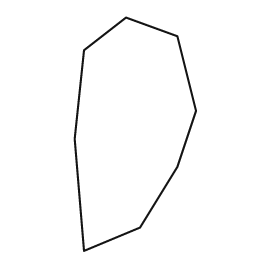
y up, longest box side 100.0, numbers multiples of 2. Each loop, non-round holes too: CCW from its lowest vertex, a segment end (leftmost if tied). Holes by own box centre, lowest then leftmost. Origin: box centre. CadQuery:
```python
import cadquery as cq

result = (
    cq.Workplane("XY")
    .moveTo(-22.0, -50.0)
    .lineTo(2.0, -40.0)
    .lineTo(18.0, -14.0)
    .lineTo(26.0, 10.0)
    .lineTo(18.0, 42.0)
    .lineTo(-4.0, 50.0)
    .lineTo(-22.0, 36.0)
    .lineTo(-26.0, -2.0)
    .close()
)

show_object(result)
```